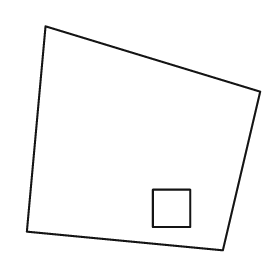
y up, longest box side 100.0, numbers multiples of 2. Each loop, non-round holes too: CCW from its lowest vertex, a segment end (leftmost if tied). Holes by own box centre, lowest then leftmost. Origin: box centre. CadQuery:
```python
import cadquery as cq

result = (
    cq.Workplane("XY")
    .moveTo(34.0, -48.0)
    .lineTo(50.0, 20.0)
    .lineTo(-42.0, 48.0)
    .lineTo(-50.0, -40.0)
    .close()
    .moveTo(4.0, -38.0)
    .lineTo(20.0, -38.0)
    .lineTo(20.0, -22.0)
    .lineTo(4.0, -22.0)
    .close()
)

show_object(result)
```